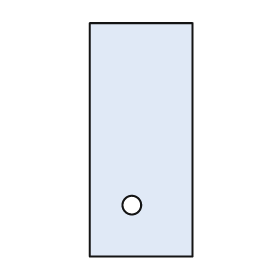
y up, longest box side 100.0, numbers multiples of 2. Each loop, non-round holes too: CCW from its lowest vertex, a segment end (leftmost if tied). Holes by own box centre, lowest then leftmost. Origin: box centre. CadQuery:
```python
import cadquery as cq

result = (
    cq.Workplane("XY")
    .moveTo(-22.0, -50.0)
    .lineTo(22.0, -50.0)
    .lineTo(22.0, 50.0)
    .lineTo(-22.0, 50.0)
    .close()
    .moveTo(-4.0, -28.0)
    .circle(4.0)
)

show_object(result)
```